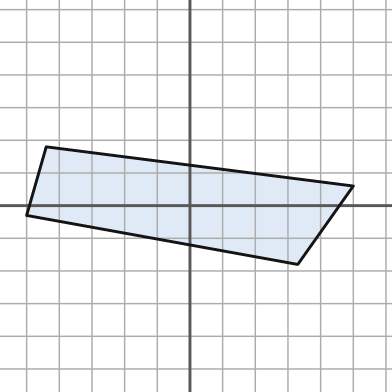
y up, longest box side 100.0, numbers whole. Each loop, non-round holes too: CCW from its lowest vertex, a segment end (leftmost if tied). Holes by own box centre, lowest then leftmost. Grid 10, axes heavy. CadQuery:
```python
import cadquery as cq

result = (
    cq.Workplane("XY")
    .moveTo(33.0, -18.0)
    .lineTo(50.0, 6.0)
    .lineTo(-44.0, 18.0)
    .lineTo(-50.0, -3.0)
    .close()
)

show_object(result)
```